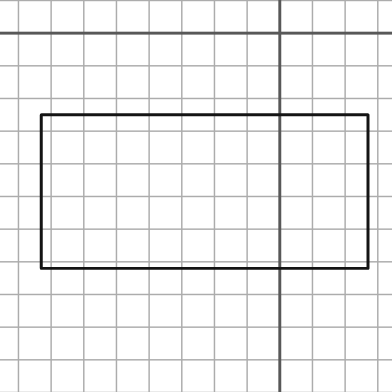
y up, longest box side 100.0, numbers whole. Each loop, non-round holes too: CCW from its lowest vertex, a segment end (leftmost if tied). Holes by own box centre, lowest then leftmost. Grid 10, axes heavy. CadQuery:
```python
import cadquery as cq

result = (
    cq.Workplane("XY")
    .moveTo(-73.0, -72.0)
    .lineTo(27.0, -72.0)
    .lineTo(27.0, -25.0)
    .lineTo(-73.0, -25.0)
    .close()
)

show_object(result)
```